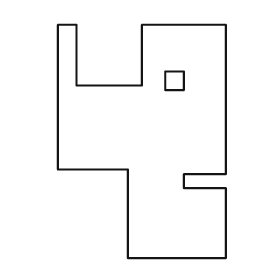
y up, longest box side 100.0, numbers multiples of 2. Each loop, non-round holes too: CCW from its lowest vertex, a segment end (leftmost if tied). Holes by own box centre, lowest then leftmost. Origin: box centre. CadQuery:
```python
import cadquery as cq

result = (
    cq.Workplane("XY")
    .moveTo(-6.0, -50.0)
    .lineTo(36.0, -50.0)
    .lineTo(36.0, -20.0)
    .lineTo(18.0, -20.0)
    .lineTo(18.0, -14.0)
    .lineTo(36.0, -14.0)
    .lineTo(36.0, 50.0)
    .lineTo(0.0, 50.0)
    .lineTo(0.0, 24.0)
    .lineTo(-28.0, 24.0)
    .lineTo(-28.0, 50.0)
    .lineTo(-36.0, 50.0)
    .lineTo(-36.0, -12.0)
    .lineTo(-6.0, -12.0)
    .close()
    .moveTo(10.0, 22.0)
    .lineTo(18.0, 22.0)
    .lineTo(18.0, 30.0)
    .lineTo(10.0, 30.0)
    .close()
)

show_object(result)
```